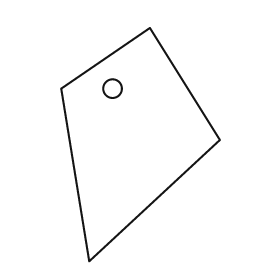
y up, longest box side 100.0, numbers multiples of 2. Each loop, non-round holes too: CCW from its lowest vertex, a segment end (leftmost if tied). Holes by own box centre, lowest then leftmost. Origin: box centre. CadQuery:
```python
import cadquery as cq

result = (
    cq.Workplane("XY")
    .moveTo(-22.0, -50.0)
    .lineTo(34.0, 2.0)
    .lineTo(4.0, 50.0)
    .lineTo(-34.0, 24.0)
    .close()
    .moveTo(-12.0, 24.0)
    .circle(4.0)
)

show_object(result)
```